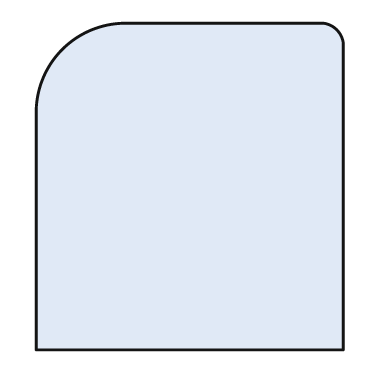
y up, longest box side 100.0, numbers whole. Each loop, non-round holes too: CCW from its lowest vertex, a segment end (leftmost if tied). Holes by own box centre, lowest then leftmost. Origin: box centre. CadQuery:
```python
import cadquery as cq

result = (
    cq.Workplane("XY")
    .moveTo(-47.0, -50.0)
    .lineTo(47.0, -50.0)
    .lineTo(47.0, 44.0)
    .threePointArc((45.0, 48.0), (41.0, 50.0))
    .lineTo(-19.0, 50.0)
    .threePointArc((-39.0, 42.0), (-47.0, 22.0))
    .close()
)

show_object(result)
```